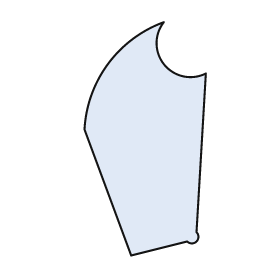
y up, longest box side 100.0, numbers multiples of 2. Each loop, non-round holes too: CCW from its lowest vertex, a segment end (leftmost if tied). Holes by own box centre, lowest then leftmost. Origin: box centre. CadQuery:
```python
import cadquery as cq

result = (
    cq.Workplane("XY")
    .moveTo(-6.0, -50.0)
    .lineTo(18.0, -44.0)
    .threePointArc((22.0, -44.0), (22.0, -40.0))
    .lineTo(26.0, 28.0)
    .threePointArc((8.0, 32.0), (8.0, 50.0))
    .threePointArc((-16.0, 32.0), (-26.0, 4.0))
    .close()
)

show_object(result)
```